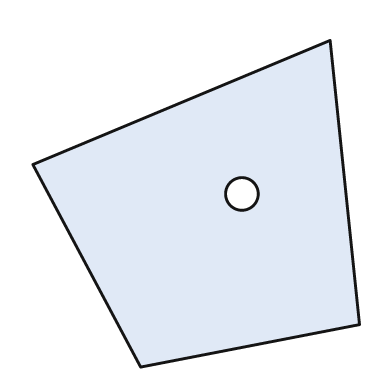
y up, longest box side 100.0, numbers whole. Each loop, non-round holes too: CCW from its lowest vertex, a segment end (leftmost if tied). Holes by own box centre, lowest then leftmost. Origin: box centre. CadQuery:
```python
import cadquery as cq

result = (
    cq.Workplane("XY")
    .moveTo(-17.0, -50.0)
    .lineTo(50.0, -37.0)
    .lineTo(41.0, 50.0)
    .lineTo(-50.0, 12.0)
    .close()
    .moveTo(14.0, 3.0)
    .circle(5.0)
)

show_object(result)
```